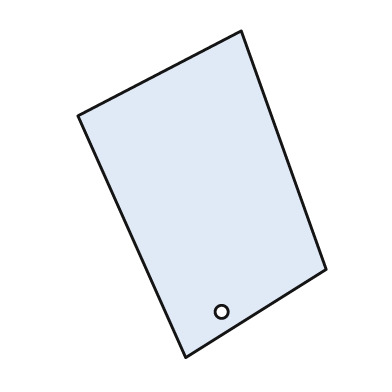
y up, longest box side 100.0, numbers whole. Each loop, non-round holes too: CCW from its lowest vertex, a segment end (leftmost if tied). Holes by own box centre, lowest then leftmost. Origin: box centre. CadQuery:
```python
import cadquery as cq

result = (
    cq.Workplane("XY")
    .moveTo(-5.0, -50.0)
    .lineTo(38.0, -23.0)
    .lineTo(12.0, 50.0)
    .lineTo(-38.0, 24.0)
    .close()
    .moveTo(6.0, -36.0)
    .circle(2.0)
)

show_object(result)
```